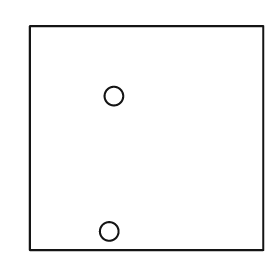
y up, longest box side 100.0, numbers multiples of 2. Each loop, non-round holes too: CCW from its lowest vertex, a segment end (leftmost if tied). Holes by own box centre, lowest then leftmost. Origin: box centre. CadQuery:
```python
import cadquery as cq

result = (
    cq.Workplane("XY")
    .moveTo(-50.0, -48.0)
    .lineTo(50.0, -48.0)
    .lineTo(50.0, 48.0)
    .lineTo(-50.0, 48.0)
    .close()
    .moveTo(-16.0, -40.0)
    .circle(4.0)
    .moveTo(-14.0, 18.0)
    .circle(4.0)
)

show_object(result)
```